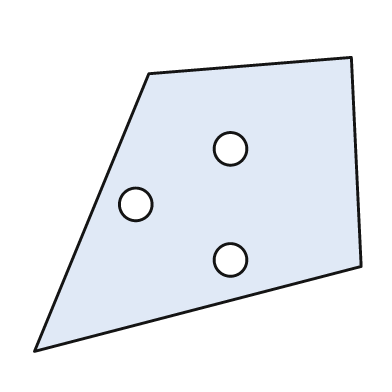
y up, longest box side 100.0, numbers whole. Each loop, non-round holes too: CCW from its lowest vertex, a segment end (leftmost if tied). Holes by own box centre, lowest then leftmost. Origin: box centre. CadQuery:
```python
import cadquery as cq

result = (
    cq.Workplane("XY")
    .moveTo(-50.0, -45.0)
    .lineTo(50.0, -19.0)
    .lineTo(47.0, 45.0)
    .lineTo(-15.0, 40.0)
    .close()
    .moveTo(10.0, -17.0)
    .circle(5.0)
    .moveTo(-19.0, 0.0)
    .circle(5.0)
    .moveTo(10.0, 17.0)
    .circle(5.0)
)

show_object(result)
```